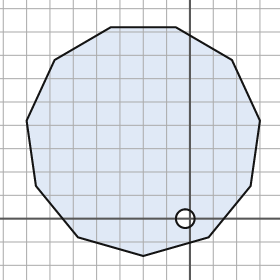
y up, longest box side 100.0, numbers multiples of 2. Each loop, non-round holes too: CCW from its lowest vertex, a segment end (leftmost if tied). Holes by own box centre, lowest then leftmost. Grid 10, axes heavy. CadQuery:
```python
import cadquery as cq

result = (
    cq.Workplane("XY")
    .moveTo(-20.0, -16.0)
    .lineTo(8.0, -8.0)
    .lineTo(26.0, 14.0)
    .lineTo(30.0, 42.0)
    .lineTo(18.0, 68.0)
    .lineTo(-6.0, 82.0)
    .lineTo(-34.0, 82.0)
    .lineTo(-58.0, 68.0)
    .lineTo(-70.0, 42.0)
    .lineTo(-66.0, 14.0)
    .lineTo(-48.0, -8.0)
    .close()
    .moveTo(-2.0, 0.0)
    .circle(4.0)
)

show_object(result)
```